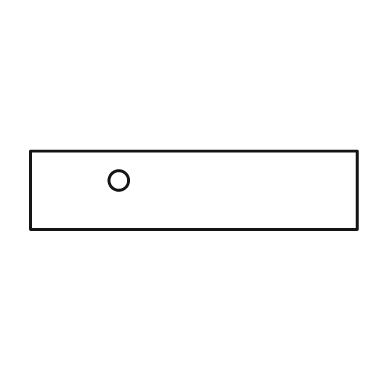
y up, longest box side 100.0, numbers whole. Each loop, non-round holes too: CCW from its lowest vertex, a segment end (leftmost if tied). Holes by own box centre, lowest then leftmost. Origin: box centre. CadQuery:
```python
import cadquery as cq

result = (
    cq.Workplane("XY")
    .moveTo(-50.0, -12.0)
    .lineTo(50.0, -12.0)
    .lineTo(50.0, 12.0)
    .lineTo(-50.0, 12.0)
    .close()
    .moveTo(-23.0, 3.0)
    .circle(3.0)
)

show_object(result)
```